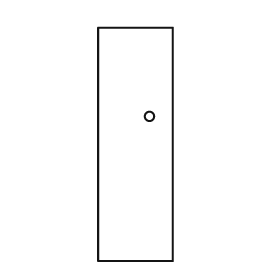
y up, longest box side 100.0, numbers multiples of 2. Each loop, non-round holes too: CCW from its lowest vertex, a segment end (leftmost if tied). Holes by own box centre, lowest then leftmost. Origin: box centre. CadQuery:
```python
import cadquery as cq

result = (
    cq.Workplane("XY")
    .moveTo(-16.0, -50.0)
    .lineTo(16.0, -50.0)
    .lineTo(16.0, 50.0)
    .lineTo(-16.0, 50.0)
    .close()
    .moveTo(6.0, 12.0)
    .circle(2.0)
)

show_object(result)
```